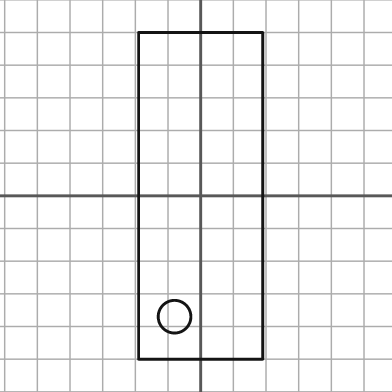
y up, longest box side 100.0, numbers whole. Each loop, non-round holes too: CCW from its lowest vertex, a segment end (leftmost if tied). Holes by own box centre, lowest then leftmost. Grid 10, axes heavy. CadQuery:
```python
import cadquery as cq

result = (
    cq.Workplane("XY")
    .moveTo(-19.0, -50.0)
    .lineTo(19.0, -50.0)
    .lineTo(19.0, 50.0)
    .lineTo(-19.0, 50.0)
    .close()
    .moveTo(-8.0, -37.0)
    .circle(5.0)
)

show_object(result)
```